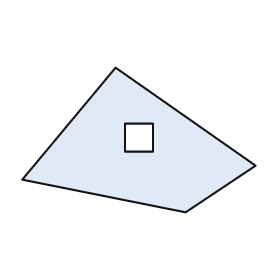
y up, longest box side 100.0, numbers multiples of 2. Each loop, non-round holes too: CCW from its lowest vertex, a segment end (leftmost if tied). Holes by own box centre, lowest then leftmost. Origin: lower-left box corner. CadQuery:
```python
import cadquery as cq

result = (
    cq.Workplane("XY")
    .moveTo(70.0, 0.0)
    .lineTo(100.0, 20.0)
    .lineTo(40.0, 62.0)
    .lineTo(0.0, 14.0)
    .close()
    .moveTo(44.0, 26.0)
    .lineTo(56.0, 26.0)
    .lineTo(56.0, 38.0)
    .lineTo(44.0, 38.0)
    .close()
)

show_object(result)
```